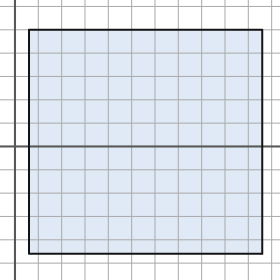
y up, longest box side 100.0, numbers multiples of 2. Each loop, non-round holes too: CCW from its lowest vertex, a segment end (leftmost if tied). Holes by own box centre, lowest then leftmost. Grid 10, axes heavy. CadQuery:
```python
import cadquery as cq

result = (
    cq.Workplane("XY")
    .moveTo(6.0, -46.0)
    .lineTo(106.0, -46.0)
    .lineTo(106.0, 50.0)
    .lineTo(6.0, 50.0)
    .close()
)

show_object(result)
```